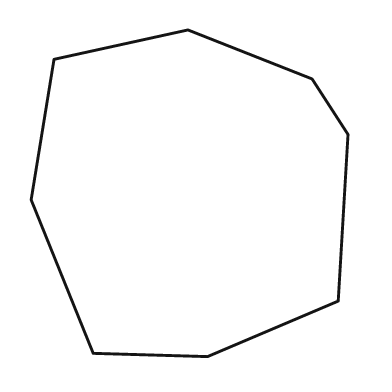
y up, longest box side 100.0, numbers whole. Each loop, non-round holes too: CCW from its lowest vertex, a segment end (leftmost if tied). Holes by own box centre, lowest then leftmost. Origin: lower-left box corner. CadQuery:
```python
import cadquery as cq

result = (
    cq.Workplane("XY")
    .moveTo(54.0, 0.0)
    .lineTo(94.0, 17.0)
    .lineTo(97.0, 68.0)
    .lineTo(86.0, 85.0)
    .lineTo(48.0, 100.0)
    .lineTo(7.0, 91.0)
    .lineTo(0.0, 48.0)
    .lineTo(19.0, 1.0)
    .close()
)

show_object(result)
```